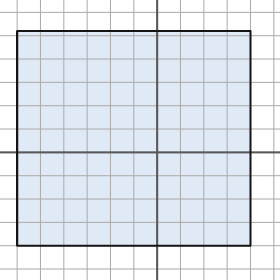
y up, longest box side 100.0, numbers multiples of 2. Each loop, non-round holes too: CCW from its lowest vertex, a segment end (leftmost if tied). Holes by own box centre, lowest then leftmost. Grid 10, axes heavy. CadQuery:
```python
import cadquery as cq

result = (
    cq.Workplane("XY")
    .moveTo(-60.0, -40.0)
    .lineTo(40.0, -40.0)
    .lineTo(40.0, 52.0)
    .lineTo(-60.0, 52.0)
    .close()
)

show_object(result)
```